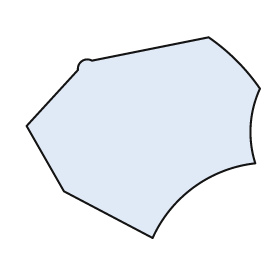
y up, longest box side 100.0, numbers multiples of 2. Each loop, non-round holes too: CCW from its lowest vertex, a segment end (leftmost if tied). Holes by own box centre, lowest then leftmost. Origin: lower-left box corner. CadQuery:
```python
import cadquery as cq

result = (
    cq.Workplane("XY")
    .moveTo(54.0, 0.0)
    .threePointArc((72.0, 22.0), (98.0, 32.0))
    .threePointArc((96.0, 48.0), (100.0, 64.0))
    .threePointArc((90.0, 76.0), (78.0, 86.0))
    .lineTo(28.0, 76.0)
    .threePointArc((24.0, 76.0), (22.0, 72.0))
    .lineTo(0.0, 48.0)
    .lineTo(16.0, 20.0)
    .close()
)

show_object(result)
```